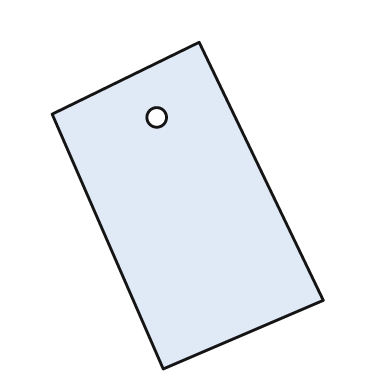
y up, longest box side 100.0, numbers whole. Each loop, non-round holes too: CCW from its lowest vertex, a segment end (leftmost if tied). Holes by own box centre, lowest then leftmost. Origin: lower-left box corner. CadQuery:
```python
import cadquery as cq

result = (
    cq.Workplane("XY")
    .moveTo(34.0, 0.0)
    .lineTo(83.0, 21.0)
    .lineTo(45.0, 100.0)
    .lineTo(0.0, 78.0)
    .close()
    .moveTo(32.0, 77.0)
    .circle(3.0)
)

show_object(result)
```